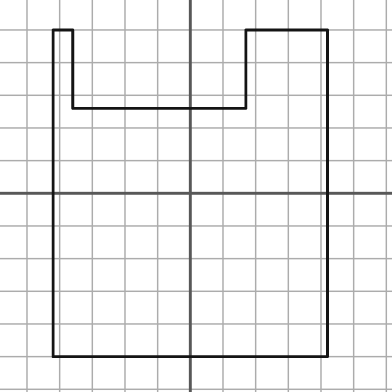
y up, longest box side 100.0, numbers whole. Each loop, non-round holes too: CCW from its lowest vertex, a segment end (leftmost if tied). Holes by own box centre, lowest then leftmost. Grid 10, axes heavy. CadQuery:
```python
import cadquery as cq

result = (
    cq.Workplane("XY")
    .moveTo(-42.0, -50.0)
    .lineTo(42.0, -50.0)
    .lineTo(42.0, 50.0)
    .lineTo(17.0, 50.0)
    .lineTo(17.0, 26.0)
    .lineTo(-36.0, 26.0)
    .lineTo(-36.0, 50.0)
    .lineTo(-42.0, 50.0)
    .close()
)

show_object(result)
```